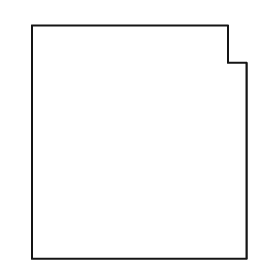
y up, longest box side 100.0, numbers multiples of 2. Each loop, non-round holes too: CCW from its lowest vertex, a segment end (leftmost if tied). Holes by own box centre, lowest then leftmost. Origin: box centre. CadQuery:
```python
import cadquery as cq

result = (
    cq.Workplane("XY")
    .moveTo(-46.0, -50.0)
    .lineTo(46.0, -50.0)
    .lineTo(46.0, 34.0)
    .lineTo(38.0, 34.0)
    .lineTo(38.0, 50.0)
    .lineTo(-46.0, 50.0)
    .close()
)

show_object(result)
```